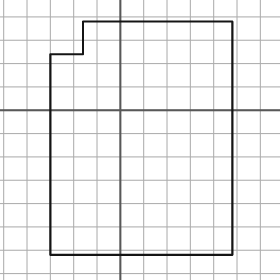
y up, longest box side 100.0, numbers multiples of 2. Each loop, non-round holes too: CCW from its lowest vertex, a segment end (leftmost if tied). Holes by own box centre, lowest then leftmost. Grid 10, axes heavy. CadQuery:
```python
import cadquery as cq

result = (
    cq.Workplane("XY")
    .moveTo(-30.0, -62.0)
    .lineTo(48.0, -62.0)
    .lineTo(48.0, 38.0)
    .lineTo(-16.0, 38.0)
    .lineTo(-16.0, 24.0)
    .lineTo(-30.0, 24.0)
    .close()
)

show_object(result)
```